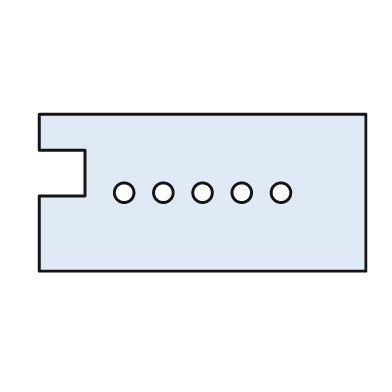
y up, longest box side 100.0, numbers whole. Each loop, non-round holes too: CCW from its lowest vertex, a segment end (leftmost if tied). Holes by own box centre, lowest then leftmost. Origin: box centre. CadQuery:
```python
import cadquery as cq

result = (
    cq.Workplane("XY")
    .moveTo(-50.0, -24.0)
    .lineTo(50.0, -24.0)
    .lineTo(50.0, 24.0)
    .lineTo(-50.0, 24.0)
    .lineTo(-50.0, 13.0)
    .lineTo(-36.0, 13.0)
    .lineTo(-36.0, -1.0)
    .lineTo(-50.0, -1.0)
    .close()
    .moveTo(-24.0, 0.0)
    .circle(3.0)
    .moveTo(-12.0, 0.0)
    .circle(3.0)
    .moveTo(0.0, 0.0)
    .circle(3.0)
    .moveTo(12.0, 0.0)
    .circle(3.0)
    .moveTo(24.0, 0.0)
    .circle(3.0)
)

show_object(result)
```